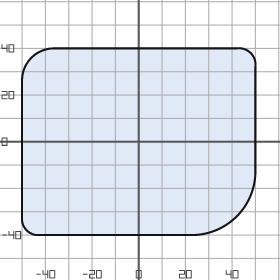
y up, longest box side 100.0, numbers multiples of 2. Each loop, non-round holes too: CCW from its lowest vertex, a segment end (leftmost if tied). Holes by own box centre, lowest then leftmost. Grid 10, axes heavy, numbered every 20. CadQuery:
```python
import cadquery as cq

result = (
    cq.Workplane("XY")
    .moveTo(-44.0, -40.0)
    .lineTo(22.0, -40.0)
    .threePointArc((42.0, -32.0), (50.0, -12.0))
    .lineTo(50.0, 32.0)
    .threePointArc((48.0, 38.0), (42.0, 40.0))
    .lineTo(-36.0, 40.0)
    .threePointArc((-46.0, 36.0), (-50.0, 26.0))
    .lineTo(-50.0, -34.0)
    .threePointArc((-48.0, -38.0), (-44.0, -40.0))
    .close()
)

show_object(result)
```